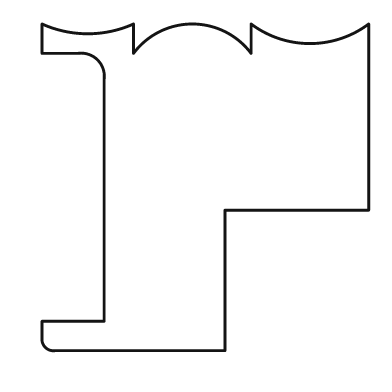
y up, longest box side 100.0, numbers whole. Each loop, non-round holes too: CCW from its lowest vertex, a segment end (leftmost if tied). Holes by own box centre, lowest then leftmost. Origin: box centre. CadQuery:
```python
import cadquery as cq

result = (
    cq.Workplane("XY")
    .moveTo(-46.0, -50.0)
    .lineTo(6.0, -50.0)
    .lineTo(6.0, -7.0)
    .lineTo(50.0, -7.0)
    .lineTo(50.0, 50.0)
    .threePointArc((32.0, 44.0), (14.0, 50.0))
    .lineTo(14.0, 41.0)
    .threePointArc((-4.0, 50.0), (-22.0, 41.0))
    .lineTo(-22.0, 50.0)
    .threePointArc((-36.0, 47.0), (-50.0, 50.0))
    .lineTo(-50.0, 41.0)
    .lineTo(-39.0, 41.0)
    .threePointArc((-33.0, 39.0), (-31.0, 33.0))
    .lineTo(-31.0, -41.0)
    .lineTo(-50.0, -41.0)
    .lineTo(-50.0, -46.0)
    .threePointArc((-49.0, -49.0), (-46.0, -50.0))
    .close()
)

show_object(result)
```